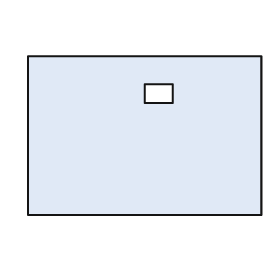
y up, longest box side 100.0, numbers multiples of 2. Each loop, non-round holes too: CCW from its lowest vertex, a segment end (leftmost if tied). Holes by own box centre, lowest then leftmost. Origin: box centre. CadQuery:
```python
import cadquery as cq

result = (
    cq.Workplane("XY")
    .moveTo(-50.0, -34.0)
    .lineTo(50.0, -34.0)
    .lineTo(50.0, 34.0)
    .lineTo(-50.0, 34.0)
    .close()
    .moveTo(0.0, 14.0)
    .lineTo(12.0, 14.0)
    .lineTo(12.0, 22.0)
    .lineTo(0.0, 22.0)
    .close()
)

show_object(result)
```